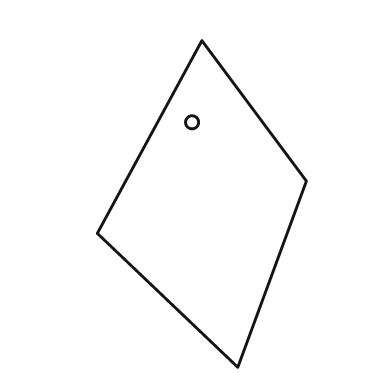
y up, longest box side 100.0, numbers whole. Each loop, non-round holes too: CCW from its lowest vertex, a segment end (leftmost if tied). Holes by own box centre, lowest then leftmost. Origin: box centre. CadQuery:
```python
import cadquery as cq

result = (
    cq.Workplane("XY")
    .moveTo(11.0, -50.0)
    .lineTo(32.0, 7.0)
    .lineTo(0.0, 50.0)
    .lineTo(-32.0, -9.0)
    .close()
    .moveTo(-3.0, 25.0)
    .circle(2.0)
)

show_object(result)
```